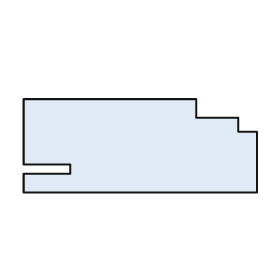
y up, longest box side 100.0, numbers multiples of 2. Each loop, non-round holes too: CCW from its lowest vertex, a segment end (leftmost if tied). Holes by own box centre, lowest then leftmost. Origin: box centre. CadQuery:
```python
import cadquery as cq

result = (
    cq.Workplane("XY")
    .moveTo(-50.0, -20.0)
    .lineTo(50.0, -20.0)
    .lineTo(50.0, 6.0)
    .lineTo(42.0, 6.0)
    .lineTo(42.0, 12.0)
    .lineTo(24.0, 12.0)
    .lineTo(24.0, 20.0)
    .lineTo(-50.0, 20.0)
    .lineTo(-50.0, -8.0)
    .lineTo(-30.0, -8.0)
    .lineTo(-30.0, -12.0)
    .lineTo(-50.0, -12.0)
    .close()
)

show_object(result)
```